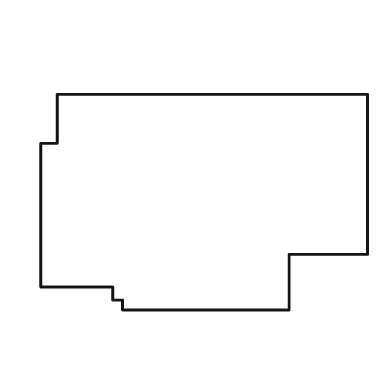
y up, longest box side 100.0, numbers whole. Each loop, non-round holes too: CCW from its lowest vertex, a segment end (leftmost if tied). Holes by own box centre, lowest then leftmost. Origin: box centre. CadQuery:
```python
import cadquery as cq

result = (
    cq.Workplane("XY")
    .moveTo(-25.0, -33.0)
    .lineTo(26.0, -33.0)
    .lineTo(26.0, -16.0)
    .lineTo(50.0, -16.0)
    .lineTo(50.0, 33.0)
    .lineTo(-45.0, 33.0)
    .lineTo(-45.0, 18.0)
    .lineTo(-50.0, 18.0)
    .lineTo(-50.0, -26.0)
    .lineTo(-28.0, -26.0)
    .lineTo(-28.0, -30.0)
    .lineTo(-25.0, -30.0)
    .close()
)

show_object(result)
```